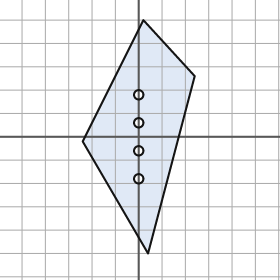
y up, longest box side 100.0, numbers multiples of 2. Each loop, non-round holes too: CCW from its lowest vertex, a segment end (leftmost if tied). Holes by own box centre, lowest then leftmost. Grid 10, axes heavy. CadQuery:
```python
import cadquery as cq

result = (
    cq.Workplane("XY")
    .moveTo(4.0, -50.0)
    .lineTo(24.0, 26.0)
    .lineTo(2.0, 50.0)
    .lineTo(-24.0, -2.0)
    .close()
    .moveTo(0.0, -18.0)
    .circle(2.0)
    .moveTo(0.0, -6.0)
    .circle(2.0)
    .moveTo(0.0, 6.0)
    .circle(2.0)
    .moveTo(0.0, 18.0)
    .circle(2.0)
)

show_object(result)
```